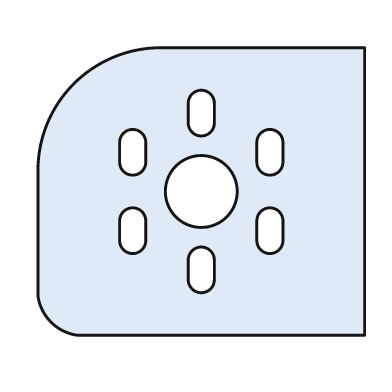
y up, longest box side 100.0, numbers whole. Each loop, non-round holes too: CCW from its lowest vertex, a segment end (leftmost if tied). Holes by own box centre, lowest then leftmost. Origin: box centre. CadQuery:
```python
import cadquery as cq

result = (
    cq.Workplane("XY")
    .moveTo(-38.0, -44.0)
    .lineTo(50.0, -44.0)
    .lineTo(50.0, 44.0)
    .lineTo(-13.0, 44.0)
    .threePointArc((-39.0, 33.0), (-50.0, 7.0))
    .lineTo(-50.0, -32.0)
    .threePointArc((-46.0, -40.0), (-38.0, -44.0))
    .close()
    .moveTo(-4.0, -27.0)
    .threePointArc((0.0, -31.0), (4.0, -27.0))
    .lineTo(4.0, -21.0)
    .threePointArc((0.0, -17.0), (-4.0, -21.0))
    .close()
    .moveTo(-25.0, -15.0)
    .threePointArc((-21.0, -19.0), (-17.0, -15.0))
    .lineTo(-17.0, -9.0)
    .threePointArc((-21.0, -5.0), (-25.0, -9.0))
    .close()
    .moveTo(17.0, -15.0)
    .threePointArc((21.0, -19.0), (25.0, -15.0))
    .lineTo(25.0, -9.0)
    .threePointArc((21.0, -5.0), (17.0, -9.0))
    .close()
    .moveTo(0.0, 0.0)
    .circle(11.0)
    .moveTo(-25.0, 9.0)
    .threePointArc((-21.0, 5.0), (-17.0, 9.0))
    .lineTo(-17.0, 15.0)
    .threePointArc((-21.0, 19.0), (-25.0, 15.0))
    .close()
    .moveTo(17.0, 9.0)
    .threePointArc((21.0, 5.0), (25.0, 9.0))
    .lineTo(25.0, 15.0)
    .threePointArc((21.0, 19.0), (17.0, 15.0))
    .close()
    .moveTo(-4.0, 21.0)
    .threePointArc((0.0, 17.0), (4.0, 21.0))
    .lineTo(4.0, 27.0)
    .threePointArc((0.0, 31.0), (-4.0, 27.0))
    .close()
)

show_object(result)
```